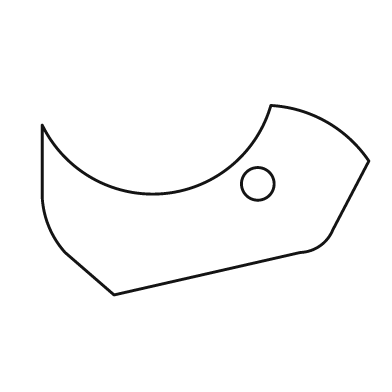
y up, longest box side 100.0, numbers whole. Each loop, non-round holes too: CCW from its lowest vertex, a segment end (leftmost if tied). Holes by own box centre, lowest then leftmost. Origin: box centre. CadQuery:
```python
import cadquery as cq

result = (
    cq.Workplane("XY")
    .moveTo(-28.0, -29.0)
    .lineTo(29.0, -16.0)
    .threePointArc((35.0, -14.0), (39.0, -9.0))
    .lineTo(50.0, 12.0)
    .threePointArc((37.0, 24.0), (20.0, 29.0))
    .threePointArc((-13.0, 2.0), (-50.0, 23.0))
    .lineTo(-50.0, 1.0)
    .threePointArc((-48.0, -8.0), (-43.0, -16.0))
    .close()
    .moveTo(16.0, 5.0)
    .circle(5.0)
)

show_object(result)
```